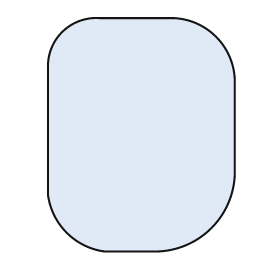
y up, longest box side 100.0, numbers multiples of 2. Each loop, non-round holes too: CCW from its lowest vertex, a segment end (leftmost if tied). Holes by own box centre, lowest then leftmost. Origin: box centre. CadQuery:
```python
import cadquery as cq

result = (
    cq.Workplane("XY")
    .moveTo(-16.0, -50.0)
    .lineTo(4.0, -50.0)
    .threePointArc((30.0, -40.0), (40.0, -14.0))
    .lineTo(40.0, 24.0)
    .threePointArc((32.0, 42.0), (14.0, 50.0))
    .lineTo(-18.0, 50.0)
    .threePointArc((-34.0, 44.0), (-40.0, 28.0))
    .lineTo(-40.0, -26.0)
    .threePointArc((-32.0, -42.0), (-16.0, -50.0))
    .close()
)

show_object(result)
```